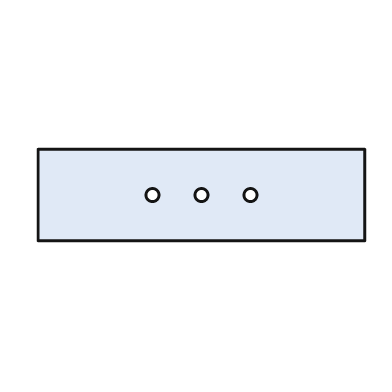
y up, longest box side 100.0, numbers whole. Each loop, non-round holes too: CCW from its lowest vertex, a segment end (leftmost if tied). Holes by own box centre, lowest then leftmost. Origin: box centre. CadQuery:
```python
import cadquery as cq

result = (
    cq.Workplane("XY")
    .moveTo(-50.0, -14.0)
    .lineTo(50.0, -14.0)
    .lineTo(50.0, 14.0)
    .lineTo(-50.0, 14.0)
    .close()
    .moveTo(-15.0, 0.0)
    .circle(2.0)
    .moveTo(0.0, 0.0)
    .circle(2.0)
    .moveTo(15.0, 0.0)
    .circle(2.0)
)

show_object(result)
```